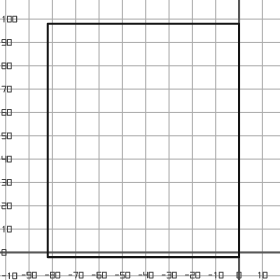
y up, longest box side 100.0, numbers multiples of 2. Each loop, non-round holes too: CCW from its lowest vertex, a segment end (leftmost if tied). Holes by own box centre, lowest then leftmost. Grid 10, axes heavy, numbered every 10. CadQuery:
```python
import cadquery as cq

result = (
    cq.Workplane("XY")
    .moveTo(-82.0, -2.0)
    .lineTo(0.0, -2.0)
    .lineTo(0.0, 98.0)
    .lineTo(-82.0, 98.0)
    .close()
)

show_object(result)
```